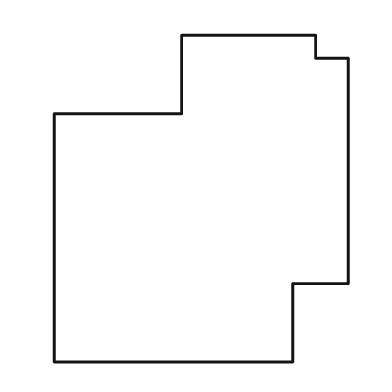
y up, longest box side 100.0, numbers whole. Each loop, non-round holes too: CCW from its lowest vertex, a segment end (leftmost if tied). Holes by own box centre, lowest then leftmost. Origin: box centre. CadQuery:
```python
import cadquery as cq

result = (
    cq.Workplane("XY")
    .moveTo(-45.0, -50.0)
    .lineTo(28.0, -50.0)
    .lineTo(28.0, -26.0)
    .lineTo(45.0, -26.0)
    .lineTo(45.0, 43.0)
    .lineTo(35.0, 43.0)
    .lineTo(35.0, 50.0)
    .lineTo(-6.0, 50.0)
    .lineTo(-6.0, 26.0)
    .lineTo(-45.0, 26.0)
    .close()
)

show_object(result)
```